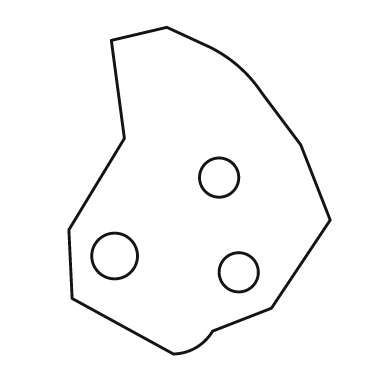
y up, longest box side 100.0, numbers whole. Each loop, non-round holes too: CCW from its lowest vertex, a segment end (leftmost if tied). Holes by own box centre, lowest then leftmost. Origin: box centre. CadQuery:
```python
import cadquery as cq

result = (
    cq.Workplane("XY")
    .moveTo(-8.0, -50.0)
    .threePointArc((-1.0, -48.0), (4.0, -43.0))
    .lineTo(22.0, -36.0)
    .lineTo(40.0, -9.0)
    .lineTo(31.0, 14.0)
    .lineTo(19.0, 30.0)
    .threePointArc((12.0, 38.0), (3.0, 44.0))
    .lineTo(-10.0, 50.0)
    .lineTo(-27.0, 46.0)
    .lineTo(-23.0, 16.0)
    .lineTo(-40.0, -12.0)
    .lineTo(-39.0, -33.0)
    .close()
    .moveTo(12.0, -25.0)
    .circle(6.0)
    .moveTo(-26.0, -20.0)
    .circle(7.0)
    .moveTo(6.0, 4.0)
    .circle(6.0)
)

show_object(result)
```